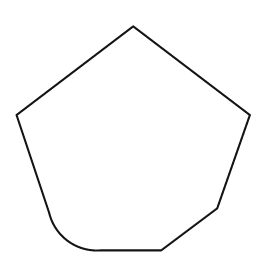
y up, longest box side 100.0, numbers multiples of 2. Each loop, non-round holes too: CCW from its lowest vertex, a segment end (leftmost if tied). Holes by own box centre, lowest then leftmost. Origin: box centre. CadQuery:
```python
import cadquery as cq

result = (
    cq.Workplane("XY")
    .moveTo(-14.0, -48.0)
    .lineTo(12.0, -48.0)
    .lineTo(36.0, -30.0)
    .lineTo(50.0, 10.0)
    .lineTo(0.0, 48.0)
    .lineTo(-50.0, 10.0)
    .lineTo(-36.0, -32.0)
    .threePointArc((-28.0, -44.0), (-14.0, -48.0))
    .close()
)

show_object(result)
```